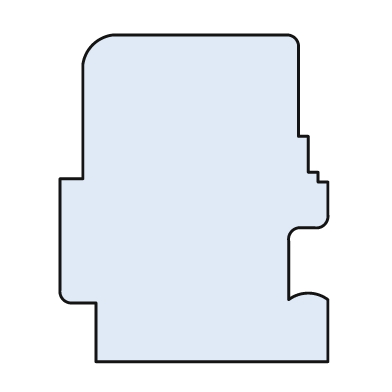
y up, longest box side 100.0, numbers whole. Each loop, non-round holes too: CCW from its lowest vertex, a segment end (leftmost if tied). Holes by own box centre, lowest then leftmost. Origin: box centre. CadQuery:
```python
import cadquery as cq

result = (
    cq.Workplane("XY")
    .moveTo(-30.0, -50.0)
    .lineTo(41.0, -50.0)
    .lineTo(41.0, -31.0)
    .threePointArc((35.0, -29.0), (29.0, -31.0))
    .lineTo(29.0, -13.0)
    .threePointArc((30.0, -10.0), (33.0, -9.0))
    .lineTo(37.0, -9.0)
    .threePointArc((40.0, -8.0), (41.0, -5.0))
    .lineTo(41.0, 5.0)
    .lineTo(38.0, 5.0)
    .lineTo(38.0, 8.0)
    .lineTo(35.0, 8.0)
    .lineTo(35.0, 19.0)
    .lineTo(32.0, 19.0)
    .lineTo(32.0, 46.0)
    .threePointArc((31.0, 49.0), (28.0, 50.0))
    .lineTo(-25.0, 50.0)
    .threePointArc((-31.0, 47.0), (-34.0, 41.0))
    .lineTo(-34.0, 6.0)
    .lineTo(-41.0, 6.0)
    .lineTo(-41.0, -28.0)
    .threePointArc((-40.0, -31.0), (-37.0, -32.0))
    .lineTo(-30.0, -32.0)
    .close()
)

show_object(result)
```